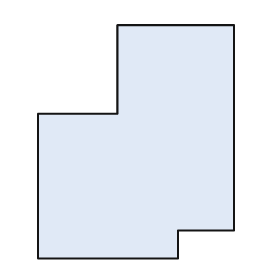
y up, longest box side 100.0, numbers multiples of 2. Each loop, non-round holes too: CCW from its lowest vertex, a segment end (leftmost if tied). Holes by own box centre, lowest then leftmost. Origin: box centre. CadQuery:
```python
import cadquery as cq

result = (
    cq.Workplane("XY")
    .moveTo(-42.0, -50.0)
    .lineTo(18.0, -50.0)
    .lineTo(18.0, -38.0)
    .lineTo(42.0, -38.0)
    .lineTo(42.0, 50.0)
    .lineTo(-8.0, 50.0)
    .lineTo(-8.0, 12.0)
    .lineTo(-42.0, 12.0)
    .close()
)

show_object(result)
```